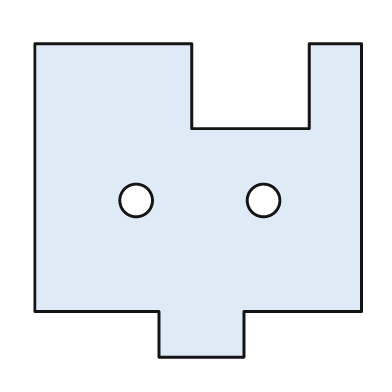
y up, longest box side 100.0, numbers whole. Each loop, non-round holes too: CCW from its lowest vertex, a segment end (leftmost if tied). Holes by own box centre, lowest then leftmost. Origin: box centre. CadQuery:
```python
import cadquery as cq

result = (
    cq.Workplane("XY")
    .moveTo(-12.0, -48.0)
    .lineTo(14.0, -48.0)
    .lineTo(14.0, -34.0)
    .lineTo(50.0, -34.0)
    .lineTo(50.0, 48.0)
    .lineTo(34.0, 48.0)
    .lineTo(34.0, 22.0)
    .lineTo(-2.0, 22.0)
    .lineTo(-2.0, 48.0)
    .lineTo(-50.0, 48.0)
    .lineTo(-50.0, -34.0)
    .lineTo(-12.0, -34.0)
    .close()
    .moveTo(-19.0, 0.0)
    .circle(5.0)
    .moveTo(20.0, 0.0)
    .circle(5.0)
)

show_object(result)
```